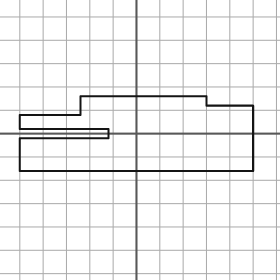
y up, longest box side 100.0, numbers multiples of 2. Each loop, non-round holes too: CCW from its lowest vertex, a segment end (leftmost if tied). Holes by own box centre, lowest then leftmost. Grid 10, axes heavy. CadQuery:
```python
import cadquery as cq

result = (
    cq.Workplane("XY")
    .moveTo(-50.0, -16.0)
    .lineTo(50.0, -16.0)
    .lineTo(50.0, 12.0)
    .lineTo(30.0, 12.0)
    .lineTo(30.0, 16.0)
    .lineTo(-24.0, 16.0)
    .lineTo(-24.0, 8.0)
    .lineTo(-50.0, 8.0)
    .lineTo(-50.0, 2.0)
    .lineTo(-12.0, 2.0)
    .lineTo(-12.0, -2.0)
    .lineTo(-50.0, -2.0)
    .close()
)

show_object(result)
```